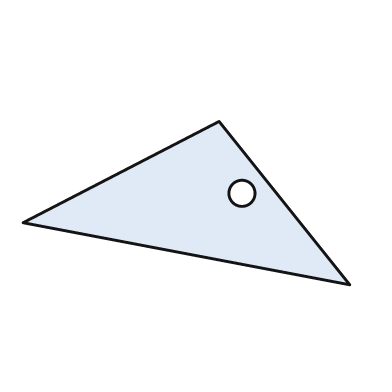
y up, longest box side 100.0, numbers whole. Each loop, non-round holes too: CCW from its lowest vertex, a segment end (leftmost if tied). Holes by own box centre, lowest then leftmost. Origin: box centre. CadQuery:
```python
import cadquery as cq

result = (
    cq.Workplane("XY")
    .moveTo(50.0, -25.0)
    .lineTo(10.0, 25.0)
    .lineTo(-50.0, -6.0)
    .close()
    .moveTo(17.0, 3.0)
    .circle(4.0)
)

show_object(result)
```